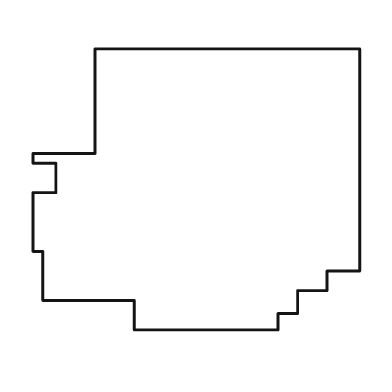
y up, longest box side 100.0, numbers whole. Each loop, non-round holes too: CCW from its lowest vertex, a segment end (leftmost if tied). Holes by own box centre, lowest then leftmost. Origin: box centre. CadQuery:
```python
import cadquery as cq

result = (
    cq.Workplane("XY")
    .moveTo(-19.0, -43.0)
    .lineTo(25.0, -43.0)
    .lineTo(25.0, -38.0)
    .lineTo(31.0, -38.0)
    .lineTo(31.0, -31.0)
    .lineTo(40.0, -31.0)
    .lineTo(40.0, -25.0)
    .lineTo(50.0, -25.0)
    .lineTo(50.0, 43.0)
    .lineTo(-31.0, 43.0)
    .lineTo(-31.0, 11.0)
    .lineTo(-50.0, 11.0)
    .lineTo(-50.0, 8.0)
    .lineTo(-43.0, 8.0)
    .lineTo(-43.0, -1.0)
    .lineTo(-50.0, -1.0)
    .lineTo(-50.0, -19.0)
    .lineTo(-47.0, -19.0)
    .lineTo(-47.0, -34.0)
    .lineTo(-19.0, -34.0)
    .close()
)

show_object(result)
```